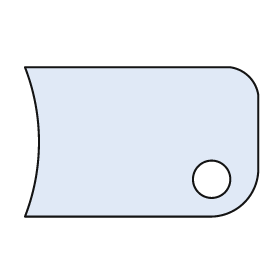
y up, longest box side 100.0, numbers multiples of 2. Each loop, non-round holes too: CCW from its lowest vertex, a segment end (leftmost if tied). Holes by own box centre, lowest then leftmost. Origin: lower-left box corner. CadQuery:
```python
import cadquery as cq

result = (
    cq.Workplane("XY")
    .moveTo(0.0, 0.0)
    .lineTo(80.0, 0.0)
    .threePointArc((94.0, 6.0), (100.0, 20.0))
    .lineTo(100.0, 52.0)
    .threePointArc((96.0, 60.0), (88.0, 64.0))
    .lineTo(0.0, 64.0)
    .threePointArc((6.0, 32.0), (0.0, 0.0))
    .close()
    .moveTo(80.0, 16.0)
    .circle(8.0)
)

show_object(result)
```